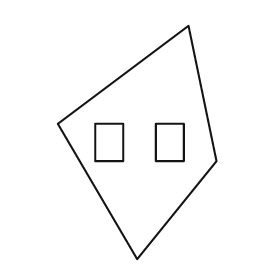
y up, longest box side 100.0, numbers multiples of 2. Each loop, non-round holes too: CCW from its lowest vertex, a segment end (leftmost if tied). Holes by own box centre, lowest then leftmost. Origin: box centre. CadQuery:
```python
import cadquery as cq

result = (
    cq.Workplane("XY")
    .moveTo(0.0, -50.0)
    .lineTo(34.0, -8.0)
    .lineTo(22.0, 50.0)
    .lineTo(-34.0, 8.0)
    .close()
    .moveTo(-18.0, -8.0)
    .lineTo(-6.0, -8.0)
    .lineTo(-6.0, 8.0)
    .lineTo(-18.0, 8.0)
    .close()
    .moveTo(8.0, -8.0)
    .lineTo(20.0, -8.0)
    .lineTo(20.0, 8.0)
    .lineTo(8.0, 8.0)
    .close()
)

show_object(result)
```